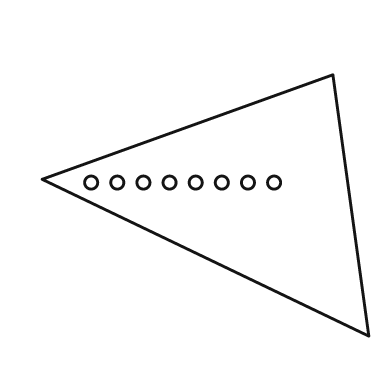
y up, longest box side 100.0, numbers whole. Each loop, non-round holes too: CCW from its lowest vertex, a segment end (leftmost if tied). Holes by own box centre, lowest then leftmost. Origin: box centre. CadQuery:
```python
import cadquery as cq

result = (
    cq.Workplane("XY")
    .moveTo(50.0, -40.0)
    .lineTo(39.0, 40.0)
    .lineTo(-50.0, 8.0)
    .close()
    .moveTo(-35.0, 7.0)
    .circle(2.0)
    .moveTo(-27.0, 7.0)
    .circle(2.0)
    .moveTo(-19.0, 7.0)
    .circle(2.0)
    .moveTo(-11.0, 7.0)
    .circle(2.0)
    .moveTo(-3.0, 7.0)
    .circle(2.0)
    .moveTo(5.0, 7.0)
    .circle(2.0)
    .moveTo(13.0, 7.0)
    .circle(2.0)
    .moveTo(21.0, 7.0)
    .circle(2.0)
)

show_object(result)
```